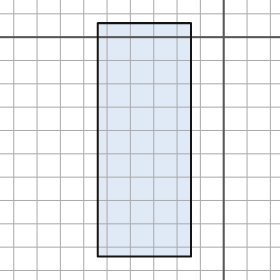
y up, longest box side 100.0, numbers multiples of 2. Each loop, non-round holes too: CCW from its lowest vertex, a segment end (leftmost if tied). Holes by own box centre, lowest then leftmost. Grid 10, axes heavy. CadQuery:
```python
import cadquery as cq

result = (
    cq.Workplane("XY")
    .moveTo(-54.0, -94.0)
    .lineTo(-14.0, -94.0)
    .lineTo(-14.0, 6.0)
    .lineTo(-54.0, 6.0)
    .close()
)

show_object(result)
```